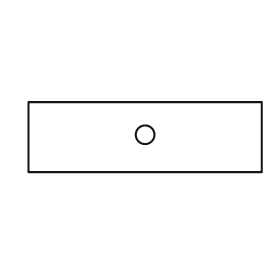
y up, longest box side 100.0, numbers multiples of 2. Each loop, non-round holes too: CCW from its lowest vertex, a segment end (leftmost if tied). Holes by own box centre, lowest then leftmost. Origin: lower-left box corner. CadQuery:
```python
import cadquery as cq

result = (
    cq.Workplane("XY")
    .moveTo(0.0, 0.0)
    .lineTo(100.0, 0.0)
    .lineTo(100.0, 30.0)
    .lineTo(0.0, 30.0)
    .close()
    .moveTo(50.0, 16.0)
    .circle(4.0)
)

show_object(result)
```